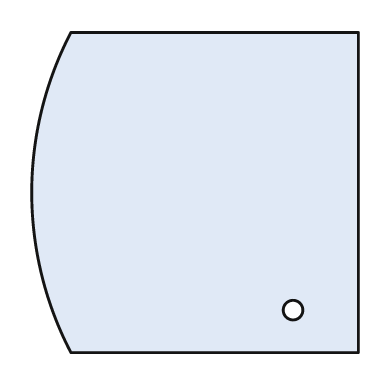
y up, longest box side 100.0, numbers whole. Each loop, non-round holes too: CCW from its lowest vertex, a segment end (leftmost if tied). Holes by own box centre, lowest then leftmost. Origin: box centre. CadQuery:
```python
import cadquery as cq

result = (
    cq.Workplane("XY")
    .moveTo(-38.0, -49.0)
    .lineTo(50.0, -49.0)
    .lineTo(50.0, 49.0)
    .lineTo(-38.0, 49.0)
    .threePointArc((-50.0, 0.0), (-38.0, -49.0))
    .close()
    .moveTo(30.0, -36.0)
    .circle(3.0)
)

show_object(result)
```